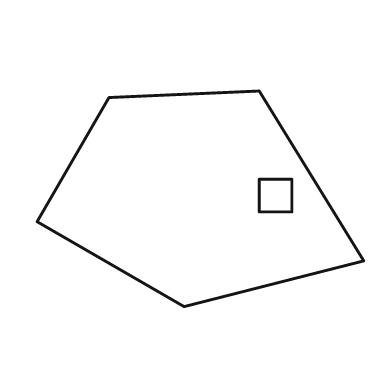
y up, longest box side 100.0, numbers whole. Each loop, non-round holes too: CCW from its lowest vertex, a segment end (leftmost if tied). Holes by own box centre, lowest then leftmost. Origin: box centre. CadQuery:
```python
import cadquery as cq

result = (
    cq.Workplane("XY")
    .moveTo(-5.0, -33.0)
    .lineTo(50.0, -19.0)
    .lineTo(18.0, 33.0)
    .lineTo(-28.0, 31.0)
    .lineTo(-50.0, -7.0)
    .close()
    .moveTo(18.0, -4.0)
    .lineTo(28.0, -4.0)
    .lineTo(28.0, 6.0)
    .lineTo(18.0, 6.0)
    .close()
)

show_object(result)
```